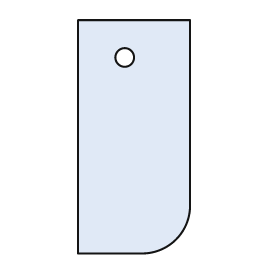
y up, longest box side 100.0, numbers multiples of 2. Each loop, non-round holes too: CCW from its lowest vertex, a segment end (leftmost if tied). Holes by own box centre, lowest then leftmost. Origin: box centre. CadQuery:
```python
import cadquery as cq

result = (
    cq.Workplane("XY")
    .moveTo(-24.0, -50.0)
    .lineTo(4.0, -50.0)
    .threePointArc((18.0, -44.0), (24.0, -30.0))
    .lineTo(24.0, 50.0)
    .lineTo(-24.0, 50.0)
    .close()
    .moveTo(-4.0, 34.0)
    .circle(4.0)
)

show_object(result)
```